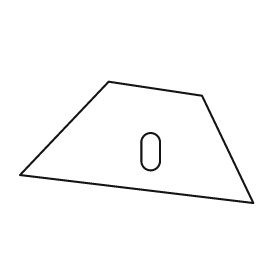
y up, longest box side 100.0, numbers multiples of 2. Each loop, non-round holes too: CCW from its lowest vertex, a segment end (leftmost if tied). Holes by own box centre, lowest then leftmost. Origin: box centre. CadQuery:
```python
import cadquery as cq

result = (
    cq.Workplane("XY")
    .moveTo(50.0, -26.0)
    .lineTo(28.0, 20.0)
    .lineTo(-12.0, 26.0)
    .lineTo(-50.0, -14.0)
    .close()
    .moveTo(2.0, -8.0)
    .threePointArc((6.0, -12.0), (10.0, -8.0))
    .lineTo(10.0, 0.0)
    .threePointArc((6.0, 4.0), (2.0, 0.0))
    .close()
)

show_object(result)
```